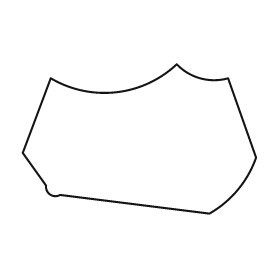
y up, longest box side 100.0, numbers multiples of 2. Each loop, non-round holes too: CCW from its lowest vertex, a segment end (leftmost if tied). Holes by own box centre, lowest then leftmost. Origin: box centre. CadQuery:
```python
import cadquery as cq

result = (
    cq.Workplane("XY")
    .moveTo(30.0, -32.0)
    .threePointArc((42.0, -22.0), (50.0, -8.0))
    .lineTo(38.0, 26.0)
    .threePointArc((26.0, 26.0), (16.0, 32.0))
    .threePointArc((-10.0, 20.0), (-38.0, 26.0))
    .lineTo(-50.0, -6.0)
    .lineTo(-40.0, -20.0)
    .threePointArc((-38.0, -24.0), (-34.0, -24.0))
    .close()
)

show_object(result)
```